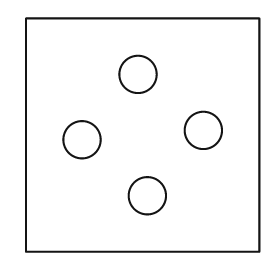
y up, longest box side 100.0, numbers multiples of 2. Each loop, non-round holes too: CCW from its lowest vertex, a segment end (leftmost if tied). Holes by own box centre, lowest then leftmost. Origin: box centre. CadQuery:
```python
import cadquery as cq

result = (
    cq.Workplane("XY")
    .moveTo(-50.0, -50.0)
    .lineTo(50.0, -50.0)
    .lineTo(50.0, 50.0)
    .lineTo(-50.0, 50.0)
    .close()
    .moveTo(2.0, -26.0)
    .circle(8.0)
    .moveTo(-26.0, -2.0)
    .circle(8.0)
    .moveTo(26.0, 2.0)
    .circle(8.0)
    .moveTo(-2.0, 26.0)
    .circle(8.0)
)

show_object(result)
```